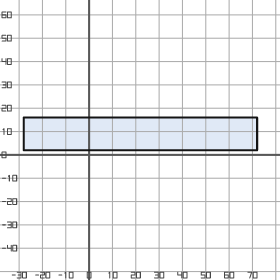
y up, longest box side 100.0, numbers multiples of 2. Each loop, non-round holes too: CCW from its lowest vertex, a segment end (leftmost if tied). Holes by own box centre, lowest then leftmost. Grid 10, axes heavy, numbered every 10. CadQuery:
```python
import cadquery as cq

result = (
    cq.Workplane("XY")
    .moveTo(-28.0, 2.0)
    .lineTo(72.0, 2.0)
    .lineTo(72.0, 16.0)
    .lineTo(-28.0, 16.0)
    .close()
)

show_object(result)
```